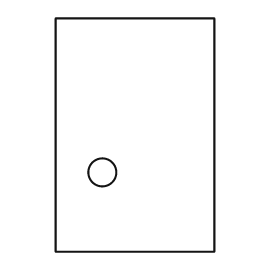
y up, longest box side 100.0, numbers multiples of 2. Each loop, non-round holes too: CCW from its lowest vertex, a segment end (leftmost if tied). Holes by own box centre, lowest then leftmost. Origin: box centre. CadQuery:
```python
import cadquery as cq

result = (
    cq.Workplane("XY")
    .moveTo(-34.0, -50.0)
    .lineTo(34.0, -50.0)
    .lineTo(34.0, 50.0)
    .lineTo(-34.0, 50.0)
    .close()
    .moveTo(-14.0, -16.0)
    .circle(6.0)
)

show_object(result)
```